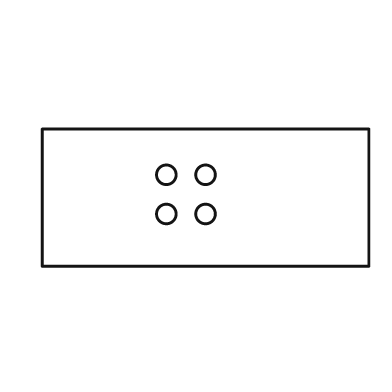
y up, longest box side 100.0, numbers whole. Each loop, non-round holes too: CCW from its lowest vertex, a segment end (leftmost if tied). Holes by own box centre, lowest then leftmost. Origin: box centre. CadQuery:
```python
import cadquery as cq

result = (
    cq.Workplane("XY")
    .moveTo(-50.0, -21.0)
    .lineTo(50.0, -21.0)
    .lineTo(50.0, 21.0)
    .lineTo(-50.0, 21.0)
    .close()
    .moveTo(-12.0, -5.0)
    .circle(3.0)
    .moveTo(0.0, -5.0)
    .circle(3.0)
    .moveTo(-12.0, 7.0)
    .circle(3.0)
    .moveTo(0.0, 7.0)
    .circle(3.0)
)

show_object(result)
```